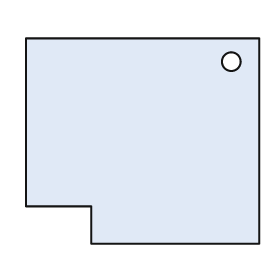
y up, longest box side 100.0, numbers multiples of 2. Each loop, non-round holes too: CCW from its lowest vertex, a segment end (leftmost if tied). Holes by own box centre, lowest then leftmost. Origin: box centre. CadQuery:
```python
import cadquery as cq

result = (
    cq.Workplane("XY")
    .moveTo(-22.0, -44.0)
    .lineTo(50.0, -44.0)
    .lineTo(50.0, 44.0)
    .lineTo(-50.0, 44.0)
    .lineTo(-50.0, -28.0)
    .lineTo(-22.0, -28.0)
    .close()
    .moveTo(38.0, 34.0)
    .circle(4.0)
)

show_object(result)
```